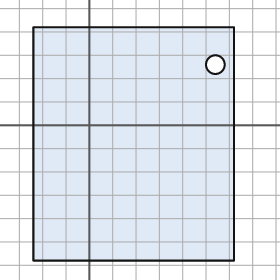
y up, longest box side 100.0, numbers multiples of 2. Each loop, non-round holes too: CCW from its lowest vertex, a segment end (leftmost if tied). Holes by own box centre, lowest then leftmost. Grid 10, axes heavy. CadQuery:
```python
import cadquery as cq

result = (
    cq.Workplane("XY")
    .moveTo(-24.0, -58.0)
    .lineTo(62.0, -58.0)
    .lineTo(62.0, 42.0)
    .lineTo(-24.0, 42.0)
    .close()
    .moveTo(54.0, 26.0)
    .circle(4.0)
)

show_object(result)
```